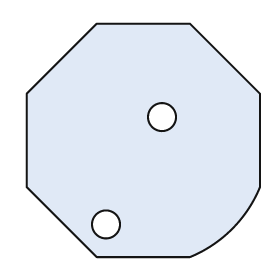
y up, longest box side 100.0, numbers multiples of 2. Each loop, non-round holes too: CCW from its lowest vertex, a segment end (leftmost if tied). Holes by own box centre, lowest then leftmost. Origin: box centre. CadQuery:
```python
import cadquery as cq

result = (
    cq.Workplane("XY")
    .moveTo(-20.0, -50.0)
    .lineTo(20.0, -50.0)
    .threePointArc((38.0, -38.0), (50.0, -20.0))
    .lineTo(50.0, 20.0)
    .lineTo(20.0, 50.0)
    .lineTo(-20.0, 50.0)
    .lineTo(-50.0, 20.0)
    .lineTo(-50.0, -20.0)
    .close()
    .moveTo(-16.0, -36.0)
    .circle(6.0)
    .moveTo(8.0, 10.0)
    .circle(6.0)
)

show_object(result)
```